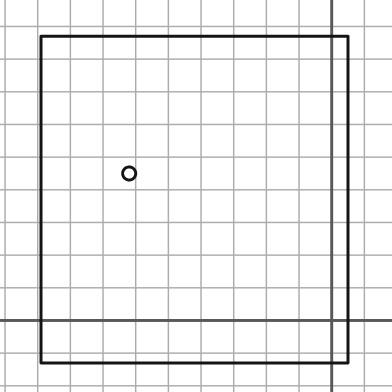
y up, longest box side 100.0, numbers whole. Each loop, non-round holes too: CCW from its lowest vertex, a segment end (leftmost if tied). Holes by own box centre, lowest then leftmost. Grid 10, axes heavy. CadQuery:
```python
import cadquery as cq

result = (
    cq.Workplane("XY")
    .moveTo(-89.0, -13.0)
    .lineTo(5.0, -13.0)
    .lineTo(5.0, 87.0)
    .lineTo(-89.0, 87.0)
    .close()
    .moveTo(-62.0, 45.0)
    .circle(2.0)
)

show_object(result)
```